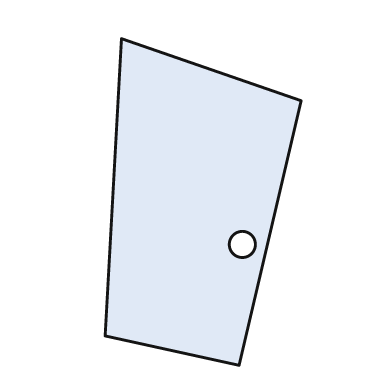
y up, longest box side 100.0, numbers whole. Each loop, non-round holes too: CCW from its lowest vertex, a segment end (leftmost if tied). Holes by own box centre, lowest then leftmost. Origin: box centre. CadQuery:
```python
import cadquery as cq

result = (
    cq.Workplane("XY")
    .moveTo(11.0, -50.0)
    .lineTo(30.0, 31.0)
    .lineTo(-25.0, 50.0)
    .lineTo(-30.0, -41.0)
    .close()
    .moveTo(12.0, -13.0)
    .circle(4.0)
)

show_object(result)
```